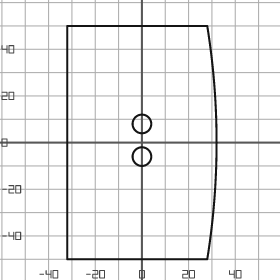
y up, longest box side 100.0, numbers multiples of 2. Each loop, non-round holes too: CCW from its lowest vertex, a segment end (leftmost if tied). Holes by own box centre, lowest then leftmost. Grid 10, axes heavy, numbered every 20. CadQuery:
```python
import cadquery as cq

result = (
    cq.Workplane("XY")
    .moveTo(-32.0, -50.0)
    .lineTo(28.0, -50.0)
    .threePointArc((32.0, 0.0), (28.0, 50.0))
    .lineTo(-32.0, 50.0)
    .close()
    .moveTo(0.0, -6.0)
    .circle(4.0)
    .moveTo(0.0, 8.0)
    .circle(4.0)
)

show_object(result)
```